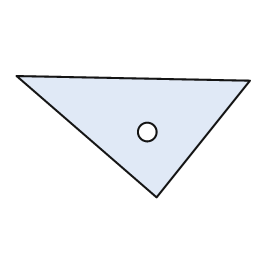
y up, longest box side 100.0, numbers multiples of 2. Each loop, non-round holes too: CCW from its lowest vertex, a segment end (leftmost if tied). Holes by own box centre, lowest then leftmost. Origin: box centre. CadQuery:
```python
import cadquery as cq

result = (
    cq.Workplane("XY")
    .moveTo(10.0, -26.0)
    .lineTo(50.0, 24.0)
    .lineTo(-50.0, 26.0)
    .close()
    .moveTo(6.0, 2.0)
    .circle(4.0)
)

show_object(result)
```